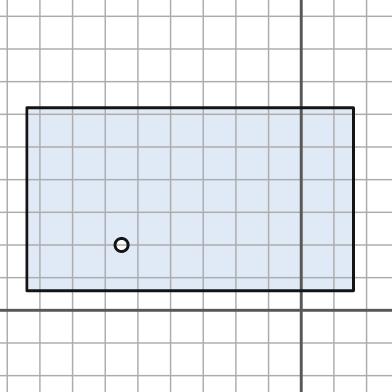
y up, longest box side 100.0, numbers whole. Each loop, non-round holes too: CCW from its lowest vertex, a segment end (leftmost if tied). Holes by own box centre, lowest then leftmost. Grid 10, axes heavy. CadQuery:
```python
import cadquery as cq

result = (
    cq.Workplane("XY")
    .moveTo(-84.0, 6.0)
    .lineTo(16.0, 6.0)
    .lineTo(16.0, 62.0)
    .lineTo(-84.0, 62.0)
    .close()
    .moveTo(-55.0, 20.0)
    .circle(2.0)
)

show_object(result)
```